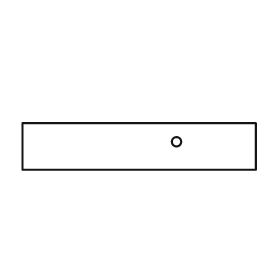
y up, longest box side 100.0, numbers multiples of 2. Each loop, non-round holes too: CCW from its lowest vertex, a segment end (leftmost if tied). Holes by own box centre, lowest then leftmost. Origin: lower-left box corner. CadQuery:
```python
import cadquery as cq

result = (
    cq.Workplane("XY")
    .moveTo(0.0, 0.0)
    .lineTo(100.0, 0.0)
    .lineTo(100.0, 20.0)
    .lineTo(0.0, 20.0)
    .close()
    .moveTo(66.0, 12.0)
    .circle(2.0)
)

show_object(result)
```